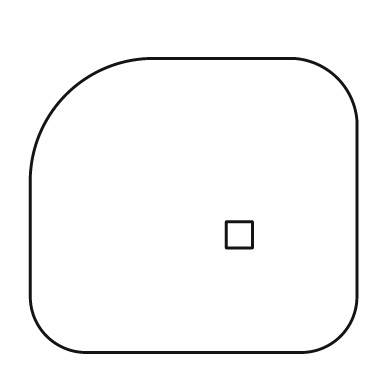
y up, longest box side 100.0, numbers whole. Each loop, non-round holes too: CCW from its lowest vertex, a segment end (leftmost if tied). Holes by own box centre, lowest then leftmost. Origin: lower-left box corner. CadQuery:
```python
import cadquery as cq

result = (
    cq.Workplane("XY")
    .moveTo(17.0, 0.0)
    .lineTo(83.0, 0.0)
    .threePointArc((95.0, 5.0), (100.0, 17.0))
    .lineTo(100.0, 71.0)
    .threePointArc((94.0, 84.0), (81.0, 90.0))
    .lineTo(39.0, 90.0)
    .threePointArc((11.0, 79.0), (0.0, 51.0))
    .lineTo(0.0, 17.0)
    .threePointArc((5.0, 5.0), (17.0, 0.0))
    .close()
    .moveTo(60.0, 32.0)
    .lineTo(68.0, 32.0)
    .lineTo(68.0, 40.0)
    .lineTo(60.0, 40.0)
    .close()
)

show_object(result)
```